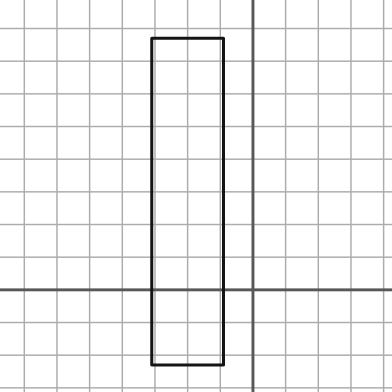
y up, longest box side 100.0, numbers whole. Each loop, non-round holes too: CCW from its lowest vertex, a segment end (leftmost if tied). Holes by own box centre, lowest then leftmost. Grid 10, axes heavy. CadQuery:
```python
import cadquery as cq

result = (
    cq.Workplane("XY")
    .moveTo(-31.0, -23.0)
    .lineTo(-9.0, -23.0)
    .lineTo(-9.0, 77.0)
    .lineTo(-31.0, 77.0)
    .close()
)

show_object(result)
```